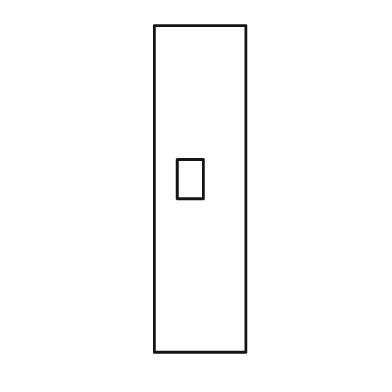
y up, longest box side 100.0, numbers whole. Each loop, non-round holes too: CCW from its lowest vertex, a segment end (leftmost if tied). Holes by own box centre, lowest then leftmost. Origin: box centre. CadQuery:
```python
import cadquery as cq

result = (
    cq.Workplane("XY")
    .moveTo(-14.0, -50.0)
    .lineTo(14.0, -50.0)
    .lineTo(14.0, 50.0)
    .lineTo(-14.0, 50.0)
    .close()
    .moveTo(-7.0, -3.0)
    .lineTo(1.0, -3.0)
    .lineTo(1.0, 9.0)
    .lineTo(-7.0, 9.0)
    .close()
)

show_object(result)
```